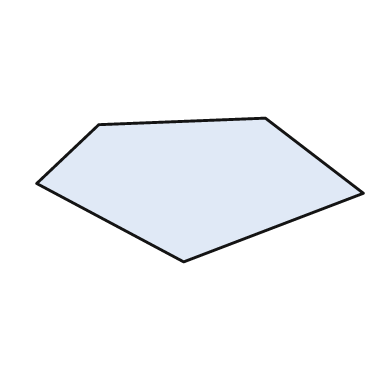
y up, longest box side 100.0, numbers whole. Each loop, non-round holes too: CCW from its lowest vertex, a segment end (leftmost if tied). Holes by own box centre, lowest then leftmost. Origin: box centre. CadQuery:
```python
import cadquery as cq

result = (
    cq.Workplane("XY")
    .moveTo(-5.0, -22.0)
    .lineTo(50.0, -1.0)
    .lineTo(20.0, 22.0)
    .lineTo(-31.0, 20.0)
    .lineTo(-50.0, 2.0)
    .close()
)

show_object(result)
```